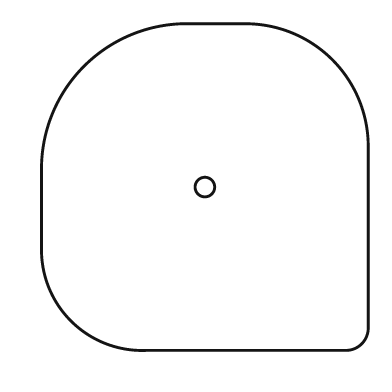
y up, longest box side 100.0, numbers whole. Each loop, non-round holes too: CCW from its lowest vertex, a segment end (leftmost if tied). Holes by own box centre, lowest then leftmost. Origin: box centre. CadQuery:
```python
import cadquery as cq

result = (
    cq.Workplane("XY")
    .moveTo(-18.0, -50.0)
    .lineTo(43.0, -50.0)
    .threePointArc((48.0, -48.0), (50.0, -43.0))
    .lineTo(50.0, 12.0)
    .threePointArc((39.0, 39.0), (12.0, 50.0))
    .lineTo(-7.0, 50.0)
    .threePointArc((-37.0, 37.0), (-50.0, 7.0))
    .lineTo(-50.0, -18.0)
    .threePointArc((-41.0, -41.0), (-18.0, -50.0))
    .close()
    .moveTo(0.0, 0.0)
    .circle(3.0)
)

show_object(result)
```